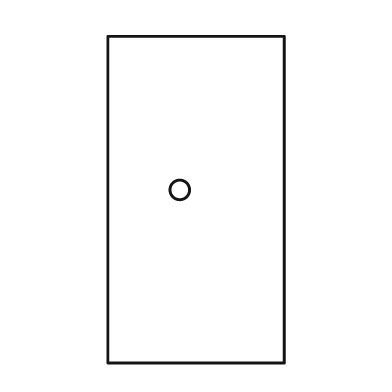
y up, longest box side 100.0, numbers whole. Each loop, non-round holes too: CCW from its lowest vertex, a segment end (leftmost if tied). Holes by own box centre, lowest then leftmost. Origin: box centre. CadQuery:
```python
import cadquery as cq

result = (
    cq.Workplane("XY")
    .moveTo(-27.0, -50.0)
    .lineTo(27.0, -50.0)
    .lineTo(27.0, 50.0)
    .lineTo(-27.0, 50.0)
    .close()
    .moveTo(-5.0, 3.0)
    .circle(3.0)
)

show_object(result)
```